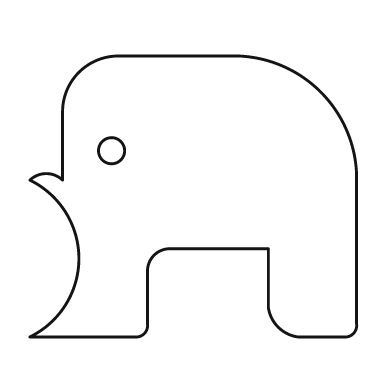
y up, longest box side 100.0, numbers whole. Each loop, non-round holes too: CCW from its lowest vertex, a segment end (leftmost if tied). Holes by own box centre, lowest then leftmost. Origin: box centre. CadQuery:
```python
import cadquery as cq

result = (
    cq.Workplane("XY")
    .moveTo(-50.0, -43.0)
    .lineTo(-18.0, -43.0)
    .threePointArc((-15.0, -42.0), (-14.0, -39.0))
    .lineTo(-14.0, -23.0)
    .threePointArc((-12.0, -18.0), (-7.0, -16.0))
    .lineTo(23.0, -16.0)
    .lineTo(23.0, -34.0)
    .threePointArc((26.0, -40.0), (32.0, -43.0))
    .lineTo(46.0, -43.0)
    .threePointArc((49.0, -42.0), (50.0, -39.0))
    .lineTo(50.0, 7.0)
    .threePointArc((39.0, 32.0), (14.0, 43.0))
    .lineTo(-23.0, 43.0)
    .threePointArc((-35.0, 38.0), (-40.0, 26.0))
    .lineTo(-40.0, 5.0)
    .threePointArc((-45.0, 7.0), (-50.0, 5.0))
    .threePointArc((-35.0, -19.0), (-50.0, -43.0))
    .close()
    .moveTo(-25.0, 14.0)
    .circle(4.0)
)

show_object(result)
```